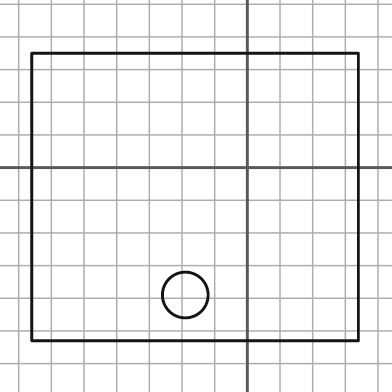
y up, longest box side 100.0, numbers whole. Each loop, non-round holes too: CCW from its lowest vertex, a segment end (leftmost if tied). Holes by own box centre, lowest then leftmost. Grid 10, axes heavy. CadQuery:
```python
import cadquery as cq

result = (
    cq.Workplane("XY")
    .moveTo(-66.0, -53.0)
    .lineTo(34.0, -53.0)
    .lineTo(34.0, 35.0)
    .lineTo(-66.0, 35.0)
    .close()
    .moveTo(-19.0, -39.0)
    .circle(7.0)
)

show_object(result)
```